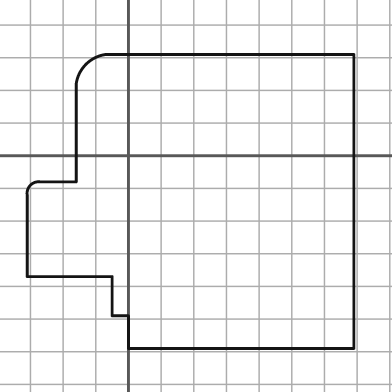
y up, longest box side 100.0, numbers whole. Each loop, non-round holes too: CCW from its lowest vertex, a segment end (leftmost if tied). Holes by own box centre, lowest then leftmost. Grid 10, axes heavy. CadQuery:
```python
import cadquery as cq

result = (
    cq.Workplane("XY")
    .moveTo(0.0, -59.0)
    .lineTo(69.0, -59.0)
    .lineTo(69.0, 31.0)
    .lineTo(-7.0, 31.0)
    .threePointArc((-13.0, 28.0), (-16.0, 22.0))
    .lineTo(-16.0, -8.0)
    .lineTo(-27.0, -8.0)
    .threePointArc((-30.0, -9.0), (-31.0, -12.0))
    .lineTo(-31.0, -37.0)
    .lineTo(-5.0, -37.0)
    .lineTo(-5.0, -49.0)
    .lineTo(0.0, -49.0)
    .close()
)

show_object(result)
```